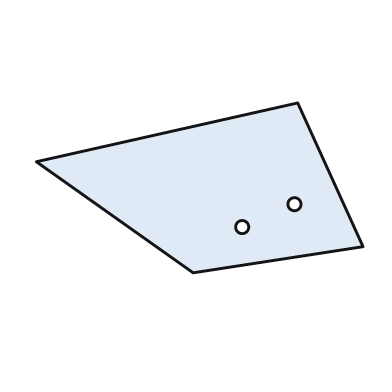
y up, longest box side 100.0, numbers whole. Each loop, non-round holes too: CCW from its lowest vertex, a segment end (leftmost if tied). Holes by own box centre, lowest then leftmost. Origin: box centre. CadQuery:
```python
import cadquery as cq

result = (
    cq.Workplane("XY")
    .moveTo(-2.0, -26.0)
    .lineTo(50.0, -18.0)
    .lineTo(30.0, 26.0)
    .lineTo(-50.0, 8.0)
    .close()
    .moveTo(13.0, -12.0)
    .circle(2.0)
    .moveTo(29.0, -5.0)
    .circle(2.0)
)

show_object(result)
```